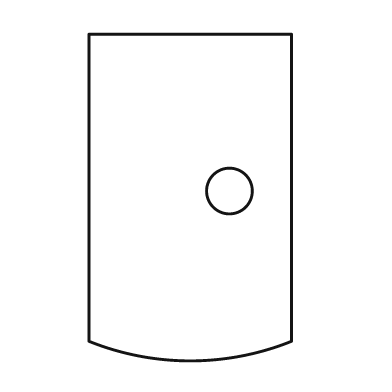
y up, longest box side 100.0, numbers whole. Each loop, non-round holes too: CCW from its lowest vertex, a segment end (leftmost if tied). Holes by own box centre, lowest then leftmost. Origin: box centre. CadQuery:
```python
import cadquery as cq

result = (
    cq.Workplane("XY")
    .moveTo(-31.0, -44.0)
    .threePointArc((0.0, -50.0), (31.0, -44.0))
    .lineTo(31.0, 50.0)
    .lineTo(-31.0, 50.0)
    .close()
    .moveTo(12.0, 2.0)
    .circle(7.0)
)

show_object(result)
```